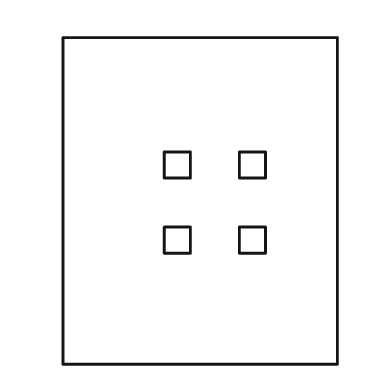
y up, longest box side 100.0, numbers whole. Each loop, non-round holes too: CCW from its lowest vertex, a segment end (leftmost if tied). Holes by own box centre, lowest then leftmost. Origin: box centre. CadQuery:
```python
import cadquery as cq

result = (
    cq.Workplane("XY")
    .moveTo(-42.0, -50.0)
    .lineTo(42.0, -50.0)
    .lineTo(42.0, 50.0)
    .lineTo(-42.0, 50.0)
    .close()
    .moveTo(-11.0, -16.0)
    .lineTo(-3.0, -16.0)
    .lineTo(-3.0, -8.0)
    .lineTo(-11.0, -8.0)
    .close()
    .moveTo(12.0, -16.0)
    .lineTo(20.0, -16.0)
    .lineTo(20.0, -8.0)
    .lineTo(12.0, -8.0)
    .close()
    .moveTo(-11.0, 7.0)
    .lineTo(-3.0, 7.0)
    .lineTo(-3.0, 15.0)
    .lineTo(-11.0, 15.0)
    .close()
    .moveTo(12.0, 7.0)
    .lineTo(20.0, 7.0)
    .lineTo(20.0, 15.0)
    .lineTo(12.0, 15.0)
    .close()
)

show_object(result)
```